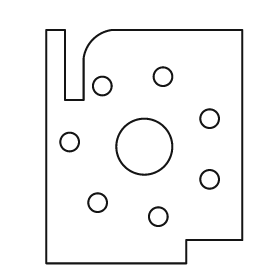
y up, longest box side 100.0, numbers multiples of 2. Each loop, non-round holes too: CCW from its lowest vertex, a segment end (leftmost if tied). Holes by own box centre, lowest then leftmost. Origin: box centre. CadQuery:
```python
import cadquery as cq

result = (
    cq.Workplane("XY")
    .moveTo(-42.0, -50.0)
    .lineTo(18.0, -50.0)
    .lineTo(18.0, -40.0)
    .lineTo(42.0, -40.0)
    .lineTo(42.0, 50.0)
    .lineTo(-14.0, 50.0)
    .threePointArc((-22.0, 46.0), (-26.0, 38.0))
    .lineTo(-26.0, 20.0)
    .lineTo(-34.0, 20.0)
    .lineTo(-34.0, 50.0)
    .lineTo(-42.0, 50.0)
    .close()
    .moveTo(6.0, -30.0)
    .circle(4.0)
    .moveTo(-20.0, -24.0)
    .circle(4.0)
    .moveTo(28.0, -14.0)
    .circle(4.0)
    .moveTo(0.0, 0.0)
    .circle(12.0)
    .moveTo(-32.0, 2.0)
    .circle(4.0)
    .moveTo(28.0, 12.0)
    .circle(4.0)
    .moveTo(-18.0, 26.0)
    .circle(4.0)
    .moveTo(8.0, 30.0)
    .circle(4.0)
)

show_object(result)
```